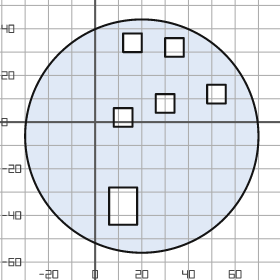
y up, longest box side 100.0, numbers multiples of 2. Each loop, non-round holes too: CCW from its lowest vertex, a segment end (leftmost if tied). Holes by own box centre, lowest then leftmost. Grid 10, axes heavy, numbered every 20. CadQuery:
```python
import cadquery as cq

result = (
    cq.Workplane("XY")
    .moveTo(20.0, -6.0)
    .circle(50.0)
    .moveTo(6.0, -44.0)
    .lineTo(18.0, -44.0)
    .lineTo(18.0, -28.0)
    .lineTo(6.0, -28.0)
    .close()
    .moveTo(8.0, -2.0)
    .lineTo(16.0, -2.0)
    .lineTo(16.0, 6.0)
    .lineTo(8.0, 6.0)
    .close()
    .moveTo(26.0, 4.0)
    .lineTo(34.0, 4.0)
    .lineTo(34.0, 12.0)
    .lineTo(26.0, 12.0)
    .close()
    .moveTo(48.0, 8.0)
    .lineTo(56.0, 8.0)
    .lineTo(56.0, 16.0)
    .lineTo(48.0, 16.0)
    .close()
    .moveTo(30.0, 28.0)
    .lineTo(38.0, 28.0)
    .lineTo(38.0, 36.0)
    .lineTo(30.0, 36.0)
    .close()
    .moveTo(12.0, 30.0)
    .lineTo(20.0, 30.0)
    .lineTo(20.0, 38.0)
    .lineTo(12.0, 38.0)
    .close()
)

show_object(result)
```